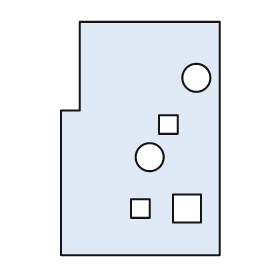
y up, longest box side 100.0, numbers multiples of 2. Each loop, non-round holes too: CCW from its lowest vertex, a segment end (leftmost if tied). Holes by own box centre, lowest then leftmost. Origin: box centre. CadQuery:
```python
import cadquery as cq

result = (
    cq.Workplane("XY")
    .moveTo(-34.0, -50.0)
    .lineTo(34.0, -50.0)
    .lineTo(34.0, 50.0)
    .lineTo(-26.0, 50.0)
    .lineTo(-26.0, 12.0)
    .lineTo(-34.0, 12.0)
    .close()
    .moveTo(-4.0, -34.0)
    .lineTo(4.0, -34.0)
    .lineTo(4.0, -26.0)
    .lineTo(-4.0, -26.0)
    .close()
    .moveTo(14.0, -36.0)
    .lineTo(26.0, -36.0)
    .lineTo(26.0, -24.0)
    .lineTo(14.0, -24.0)
    .close()
    .moveTo(4.0, -8.0)
    .circle(6.0)
    .moveTo(8.0, 2.0)
    .lineTo(16.0, 2.0)
    .lineTo(16.0, 10.0)
    .lineTo(8.0, 10.0)
    .close()
    .moveTo(24.0, 26.0)
    .circle(6.0)
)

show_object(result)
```